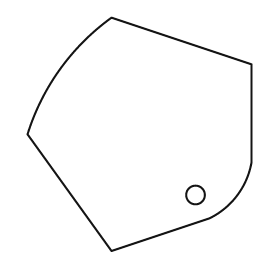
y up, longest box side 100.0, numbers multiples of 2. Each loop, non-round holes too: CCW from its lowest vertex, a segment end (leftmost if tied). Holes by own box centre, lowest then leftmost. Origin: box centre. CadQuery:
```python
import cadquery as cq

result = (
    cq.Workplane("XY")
    .moveTo(-12.0, -50.0)
    .lineTo(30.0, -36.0)
    .threePointArc((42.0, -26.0), (48.0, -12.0))
    .lineTo(48.0, 30.0)
    .lineTo(-12.0, 50.0)
    .threePointArc((-34.0, 28.0), (-48.0, 0.0))
    .close()
    .moveTo(24.0, -26.0)
    .circle(4.0)
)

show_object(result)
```